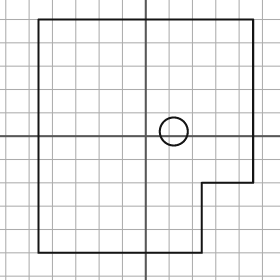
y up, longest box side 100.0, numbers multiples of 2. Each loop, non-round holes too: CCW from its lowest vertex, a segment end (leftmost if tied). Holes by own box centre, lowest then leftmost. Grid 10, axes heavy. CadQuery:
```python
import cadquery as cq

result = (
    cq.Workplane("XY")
    .moveTo(-46.0, -50.0)
    .lineTo(24.0, -50.0)
    .lineTo(24.0, -20.0)
    .lineTo(46.0, -20.0)
    .lineTo(46.0, 50.0)
    .lineTo(-46.0, 50.0)
    .close()
    .moveTo(12.0, 2.0)
    .circle(6.0)
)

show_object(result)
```